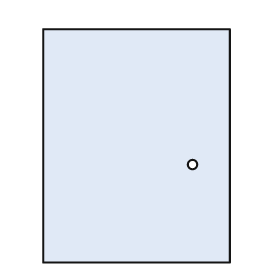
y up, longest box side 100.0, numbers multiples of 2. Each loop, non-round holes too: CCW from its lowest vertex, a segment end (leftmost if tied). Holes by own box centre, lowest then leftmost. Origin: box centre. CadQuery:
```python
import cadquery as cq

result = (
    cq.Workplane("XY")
    .moveTo(-40.0, -50.0)
    .lineTo(40.0, -50.0)
    .lineTo(40.0, 50.0)
    .lineTo(-40.0, 50.0)
    .close()
    .moveTo(24.0, -8.0)
    .circle(2.0)
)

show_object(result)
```